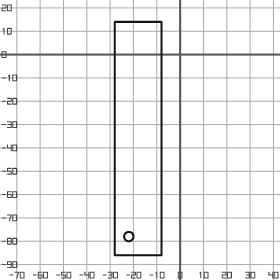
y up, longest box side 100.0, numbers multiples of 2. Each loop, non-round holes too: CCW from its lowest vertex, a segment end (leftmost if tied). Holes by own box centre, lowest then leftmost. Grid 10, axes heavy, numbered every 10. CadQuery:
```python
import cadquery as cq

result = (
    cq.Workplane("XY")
    .moveTo(-28.0, -86.0)
    .lineTo(-8.0, -86.0)
    .lineTo(-8.0, 14.0)
    .lineTo(-28.0, 14.0)
    .close()
    .moveTo(-22.0, -78.0)
    .circle(2.0)
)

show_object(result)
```